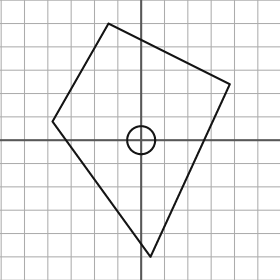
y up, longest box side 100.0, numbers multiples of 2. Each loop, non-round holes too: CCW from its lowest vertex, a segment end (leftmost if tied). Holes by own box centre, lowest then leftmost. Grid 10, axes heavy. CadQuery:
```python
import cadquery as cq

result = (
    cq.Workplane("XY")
    .moveTo(4.0, -50.0)
    .lineTo(38.0, 24.0)
    .lineTo(-14.0, 50.0)
    .lineTo(-38.0, 8.0)
    .close()
    .moveTo(0.0, 0.0)
    .circle(6.0)
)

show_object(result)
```